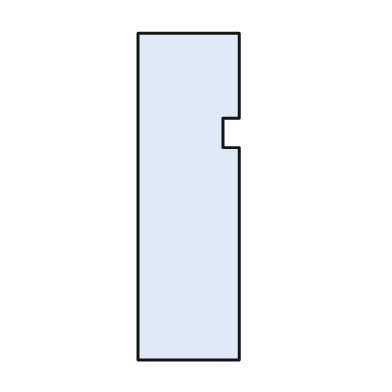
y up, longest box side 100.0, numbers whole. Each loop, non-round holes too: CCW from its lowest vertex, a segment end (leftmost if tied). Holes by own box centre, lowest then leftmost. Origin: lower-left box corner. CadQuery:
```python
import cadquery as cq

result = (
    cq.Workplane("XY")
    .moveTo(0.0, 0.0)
    .lineTo(31.0, 0.0)
    .lineTo(31.0, 65.0)
    .lineTo(26.0, 65.0)
    .lineTo(26.0, 74.0)
    .lineTo(31.0, 74.0)
    .lineTo(31.0, 100.0)
    .lineTo(0.0, 100.0)
    .close()
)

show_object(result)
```